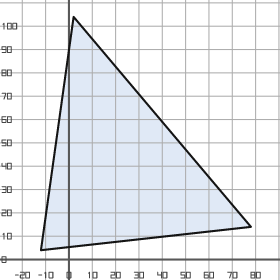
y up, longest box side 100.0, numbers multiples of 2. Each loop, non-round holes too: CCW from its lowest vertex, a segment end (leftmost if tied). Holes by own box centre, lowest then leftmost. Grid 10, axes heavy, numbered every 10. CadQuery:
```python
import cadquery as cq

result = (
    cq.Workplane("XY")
    .moveTo(-12.0, 4.0)
    .lineTo(78.0, 14.0)
    .lineTo(2.0, 104.0)
    .close()
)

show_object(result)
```